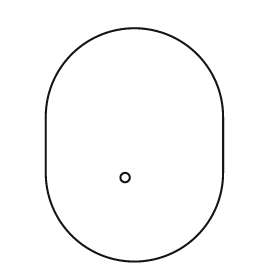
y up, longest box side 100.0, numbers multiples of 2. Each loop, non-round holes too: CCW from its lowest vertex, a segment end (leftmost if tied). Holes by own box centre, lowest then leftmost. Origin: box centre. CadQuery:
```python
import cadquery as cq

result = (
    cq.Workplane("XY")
    .moveTo(-38.0, -12.0)
    .threePointArc((0.0, -50.0), (38.0, -12.0))
    .lineTo(38.0, 12.0)
    .threePointArc((0.0, 50.0), (-38.0, 12.0))
    .close()
    .moveTo(-4.0, -14.0)
    .circle(2.0)
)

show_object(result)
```